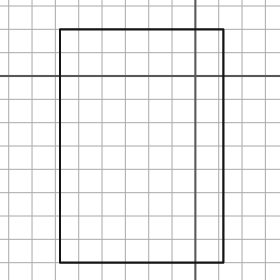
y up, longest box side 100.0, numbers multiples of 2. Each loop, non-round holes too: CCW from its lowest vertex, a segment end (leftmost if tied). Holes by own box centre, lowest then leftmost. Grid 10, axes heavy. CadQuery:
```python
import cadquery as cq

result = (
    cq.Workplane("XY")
    .moveTo(-58.0, -80.0)
    .lineTo(12.0, -80.0)
    .lineTo(12.0, 20.0)
    .lineTo(-58.0, 20.0)
    .close()
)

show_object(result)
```